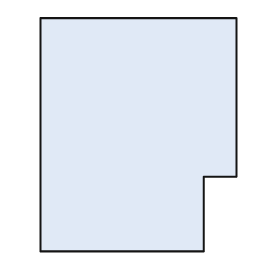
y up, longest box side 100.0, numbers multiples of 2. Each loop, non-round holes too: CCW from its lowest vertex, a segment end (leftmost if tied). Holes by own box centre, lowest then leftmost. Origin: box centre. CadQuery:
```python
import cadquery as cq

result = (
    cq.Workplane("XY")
    .moveTo(-42.0, -50.0)
    .lineTo(28.0, -50.0)
    .lineTo(28.0, -18.0)
    .lineTo(42.0, -18.0)
    .lineTo(42.0, 50.0)
    .lineTo(-42.0, 50.0)
    .close()
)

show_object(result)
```